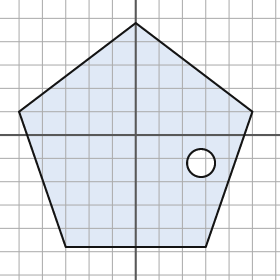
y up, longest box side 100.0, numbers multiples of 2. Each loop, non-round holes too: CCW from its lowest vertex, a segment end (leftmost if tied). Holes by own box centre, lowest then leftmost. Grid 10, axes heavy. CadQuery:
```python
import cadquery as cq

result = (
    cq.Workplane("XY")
    .moveTo(-30.0, -48.0)
    .lineTo(30.0, -48.0)
    .lineTo(50.0, 10.0)
    .lineTo(0.0, 48.0)
    .lineTo(-50.0, 10.0)
    .close()
    .moveTo(28.0, -12.0)
    .circle(6.0)
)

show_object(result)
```